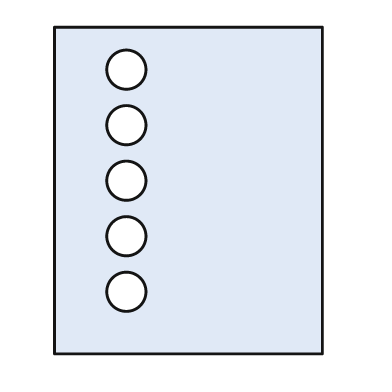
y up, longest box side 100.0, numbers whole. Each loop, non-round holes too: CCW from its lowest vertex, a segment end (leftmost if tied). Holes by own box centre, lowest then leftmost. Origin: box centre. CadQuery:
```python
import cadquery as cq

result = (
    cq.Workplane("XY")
    .moveTo(-41.0, -50.0)
    .lineTo(41.0, -50.0)
    .lineTo(41.0, 50.0)
    .lineTo(-41.0, 50.0)
    .close()
    .moveTo(-19.0, -31.0)
    .circle(6.0)
    .moveTo(-19.0, -14.0)
    .circle(6.0)
    .moveTo(-19.0, 3.0)
    .circle(6.0)
    .moveTo(-19.0, 20.0)
    .circle(6.0)
    .moveTo(-19.0, 37.0)
    .circle(6.0)
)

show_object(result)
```